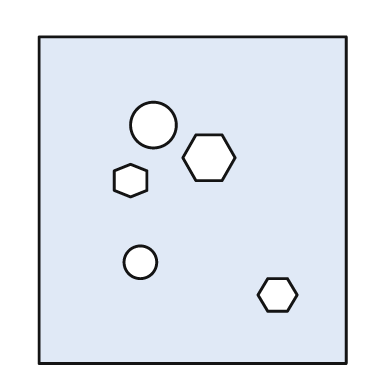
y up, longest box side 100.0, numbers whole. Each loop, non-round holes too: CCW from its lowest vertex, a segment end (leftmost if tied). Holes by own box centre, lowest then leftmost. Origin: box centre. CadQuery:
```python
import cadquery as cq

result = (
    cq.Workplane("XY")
    .moveTo(-47.0, -50.0)
    .lineTo(47.0, -50.0)
    .lineTo(47.0, 50.0)
    .lineTo(-47.0, 50.0)
    .close()
    .moveTo(23.0, -34.0)
    .lineTo(29.0, -34.0)
    .lineTo(32.0, -29.0)
    .lineTo(29.0, -24.0)
    .lineTo(23.0, -24.0)
    .lineTo(20.0, -29.0)
    .close()
    .moveTo(-16.0, -19.0)
    .circle(5.0)
    .moveTo(-19.0, 1.0)
    .lineTo(-14.0, 3.0)
    .lineTo(-14.0, 9.0)
    .lineTo(-19.0, 11.0)
    .lineTo(-24.0, 9.0)
    .lineTo(-24.0, 3.0)
    .close()
    .moveTo(1.0, 6.0)
    .lineTo(9.0, 6.0)
    .lineTo(13.0, 13.0)
    .lineTo(9.0, 20.0)
    .lineTo(1.0, 20.0)
    .lineTo(-3.0, 13.0)
    .close()
    .moveTo(-12.0, 23.0)
    .circle(7.0)
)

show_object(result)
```